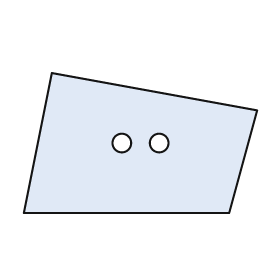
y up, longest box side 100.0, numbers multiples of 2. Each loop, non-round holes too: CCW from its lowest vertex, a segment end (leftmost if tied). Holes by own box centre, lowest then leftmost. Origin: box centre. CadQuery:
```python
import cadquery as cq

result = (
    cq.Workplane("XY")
    .moveTo(-50.0, -30.0)
    .lineTo(38.0, -30.0)
    .lineTo(50.0, 14.0)
    .lineTo(-38.0, 30.0)
    .close()
    .moveTo(-8.0, 0.0)
    .circle(4.0)
    .moveTo(8.0, 0.0)
    .circle(4.0)
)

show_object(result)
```